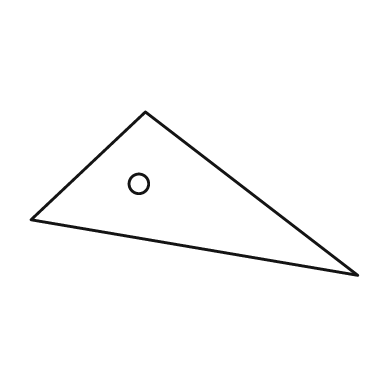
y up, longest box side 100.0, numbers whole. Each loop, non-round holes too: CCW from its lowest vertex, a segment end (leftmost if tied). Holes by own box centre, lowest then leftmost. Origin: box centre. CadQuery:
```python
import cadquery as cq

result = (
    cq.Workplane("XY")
    .moveTo(50.0, -25.0)
    .lineTo(-15.0, 25.0)
    .lineTo(-50.0, -8.0)
    .close()
    .moveTo(-17.0, 3.0)
    .circle(3.0)
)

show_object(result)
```